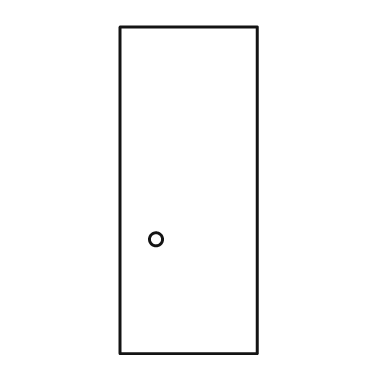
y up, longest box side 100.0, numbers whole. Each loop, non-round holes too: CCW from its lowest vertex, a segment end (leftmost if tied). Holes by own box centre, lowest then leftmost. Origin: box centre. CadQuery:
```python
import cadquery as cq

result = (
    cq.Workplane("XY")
    .moveTo(-21.0, -50.0)
    .lineTo(21.0, -50.0)
    .lineTo(21.0, 50.0)
    .lineTo(-21.0, 50.0)
    .close()
    .moveTo(-10.0, -15.0)
    .circle(2.0)
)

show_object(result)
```